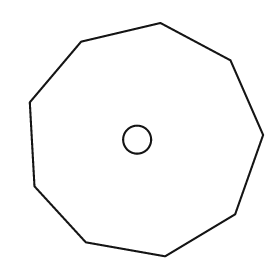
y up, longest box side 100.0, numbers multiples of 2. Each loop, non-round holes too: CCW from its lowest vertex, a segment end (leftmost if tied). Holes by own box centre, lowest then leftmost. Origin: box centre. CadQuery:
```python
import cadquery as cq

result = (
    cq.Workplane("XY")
    .moveTo(8.0, -50.0)
    .lineTo(38.0, -32.0)
    .lineTo(50.0, 2.0)
    .lineTo(36.0, 34.0)
    .lineTo(6.0, 50.0)
    .lineTo(-28.0, 42.0)
    .lineTo(-50.0, 16.0)
    .lineTo(-48.0, -20.0)
    .lineTo(-26.0, -44.0)
    .close()
    .moveTo(-4.0, 0.0)
    .circle(6.0)
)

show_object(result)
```